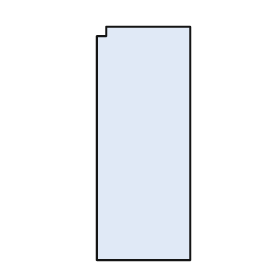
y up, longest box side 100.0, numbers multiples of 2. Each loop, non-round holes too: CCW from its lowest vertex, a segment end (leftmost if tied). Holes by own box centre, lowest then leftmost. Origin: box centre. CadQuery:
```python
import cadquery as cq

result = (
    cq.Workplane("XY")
    .moveTo(-20.0, -50.0)
    .lineTo(20.0, -50.0)
    .lineTo(20.0, 50.0)
    .lineTo(-16.0, 50.0)
    .lineTo(-16.0, 46.0)
    .lineTo(-20.0, 46.0)
    .close()
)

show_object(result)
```